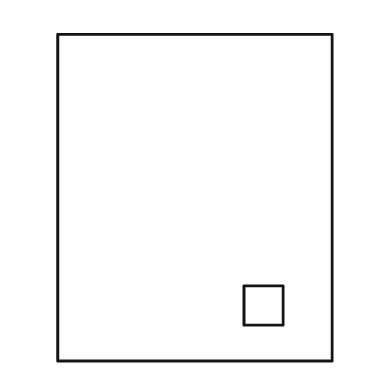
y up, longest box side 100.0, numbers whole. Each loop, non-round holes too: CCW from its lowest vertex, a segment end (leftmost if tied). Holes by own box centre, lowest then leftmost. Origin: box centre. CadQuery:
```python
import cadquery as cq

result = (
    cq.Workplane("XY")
    .moveTo(-42.0, -50.0)
    .lineTo(42.0, -50.0)
    .lineTo(42.0, 50.0)
    .lineTo(-42.0, 50.0)
    .close()
    .moveTo(15.0, -39.0)
    .lineTo(27.0, -39.0)
    .lineTo(27.0, -27.0)
    .lineTo(15.0, -27.0)
    .close()
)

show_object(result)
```